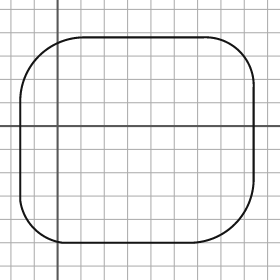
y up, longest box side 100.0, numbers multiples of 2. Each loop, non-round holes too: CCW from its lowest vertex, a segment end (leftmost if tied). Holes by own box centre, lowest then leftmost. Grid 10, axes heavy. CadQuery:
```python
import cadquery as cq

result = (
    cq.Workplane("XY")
    .moveTo(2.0, -50.0)
    .lineTo(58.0, -50.0)
    .threePointArc((76.0, -42.0), (84.0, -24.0))
    .lineTo(84.0, 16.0)
    .threePointArc((78.0, 32.0), (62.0, 38.0))
    .lineTo(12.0, 38.0)
    .threePointArc((-8.0, 30.0), (-16.0, 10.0))
    .lineTo(-16.0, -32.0)
    .threePointArc((-10.0, -44.0), (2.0, -50.0))
    .close()
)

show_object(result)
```